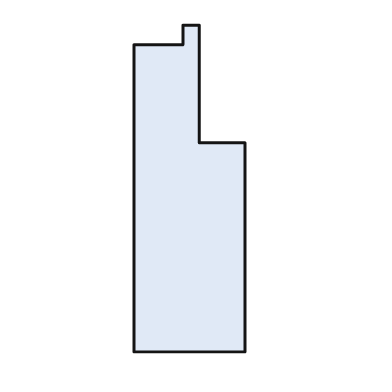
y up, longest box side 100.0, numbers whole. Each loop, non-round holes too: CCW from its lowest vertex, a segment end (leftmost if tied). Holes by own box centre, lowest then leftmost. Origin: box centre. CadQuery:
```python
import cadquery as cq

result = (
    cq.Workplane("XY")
    .moveTo(-17.0, -50.0)
    .lineTo(17.0, -50.0)
    .lineTo(17.0, 14.0)
    .lineTo(3.0, 14.0)
    .lineTo(3.0, 50.0)
    .lineTo(-2.0, 50.0)
    .lineTo(-2.0, 44.0)
    .lineTo(-17.0, 44.0)
    .close()
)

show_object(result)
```